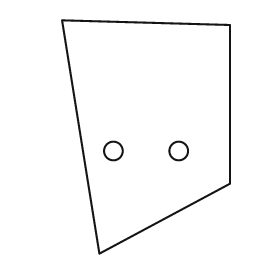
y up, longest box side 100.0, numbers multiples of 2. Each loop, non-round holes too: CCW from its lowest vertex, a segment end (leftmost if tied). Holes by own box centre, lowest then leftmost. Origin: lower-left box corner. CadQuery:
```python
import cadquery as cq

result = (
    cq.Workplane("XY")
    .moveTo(16.0, 0.0)
    .lineTo(72.0, 30.0)
    .lineTo(72.0, 98.0)
    .lineTo(0.0, 100.0)
    .close()
    .moveTo(22.0, 44.0)
    .circle(4.0)
    .moveTo(50.0, 44.0)
    .circle(4.0)
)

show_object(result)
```